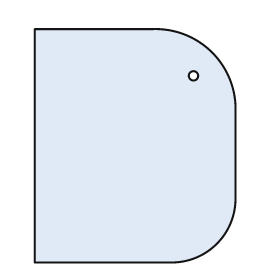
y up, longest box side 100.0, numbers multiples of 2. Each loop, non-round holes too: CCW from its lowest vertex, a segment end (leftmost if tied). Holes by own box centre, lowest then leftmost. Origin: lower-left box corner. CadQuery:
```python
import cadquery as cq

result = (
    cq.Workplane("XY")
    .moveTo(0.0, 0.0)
    .lineTo(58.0, 0.0)
    .threePointArc((78.0, 8.0), (86.0, 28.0))
    .lineTo(86.0, 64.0)
    .threePointArc((76.0, 90.0), (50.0, 100.0))
    .lineTo(0.0, 100.0)
    .close()
    .moveTo(68.0, 80.0)
    .circle(2.0)
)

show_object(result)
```